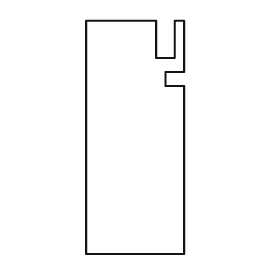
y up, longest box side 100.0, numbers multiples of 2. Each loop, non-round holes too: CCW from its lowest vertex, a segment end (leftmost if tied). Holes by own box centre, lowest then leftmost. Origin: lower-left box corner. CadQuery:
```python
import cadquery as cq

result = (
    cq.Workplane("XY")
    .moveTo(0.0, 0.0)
    .lineTo(42.0, 0.0)
    .lineTo(42.0, 72.0)
    .lineTo(34.0, 72.0)
    .lineTo(34.0, 78.0)
    .lineTo(42.0, 78.0)
    .lineTo(42.0, 100.0)
    .lineTo(38.0, 100.0)
    .lineTo(38.0, 84.0)
    .lineTo(30.0, 84.0)
    .lineTo(30.0, 100.0)
    .lineTo(0.0, 100.0)
    .close()
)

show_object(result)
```